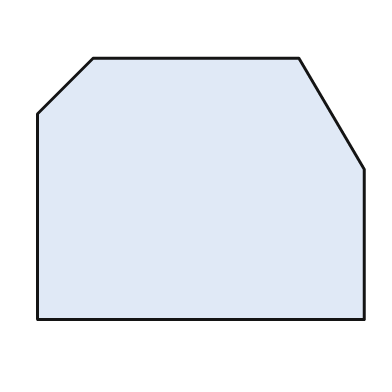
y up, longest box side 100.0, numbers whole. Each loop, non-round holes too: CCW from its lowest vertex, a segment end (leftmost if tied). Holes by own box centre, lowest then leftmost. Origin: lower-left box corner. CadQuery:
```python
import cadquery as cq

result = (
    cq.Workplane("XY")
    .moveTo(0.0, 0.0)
    .lineTo(100.0, 0.0)
    .lineTo(100.0, 46.0)
    .lineTo(80.0, 80.0)
    .lineTo(17.0, 80.0)
    .lineTo(0.0, 63.0)
    .close()
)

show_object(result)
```